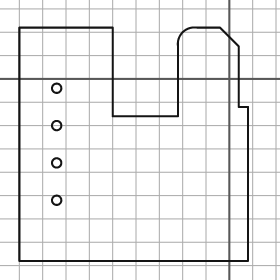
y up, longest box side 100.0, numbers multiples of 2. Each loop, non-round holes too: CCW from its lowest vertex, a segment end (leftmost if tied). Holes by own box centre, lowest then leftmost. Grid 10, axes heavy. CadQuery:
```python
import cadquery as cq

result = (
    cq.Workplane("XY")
    .moveTo(-90.0, -78.0)
    .lineTo(8.0, -78.0)
    .lineTo(8.0, -12.0)
    .lineTo(4.0, -12.0)
    .lineTo(4.0, 14.0)
    .lineTo(-4.0, 22.0)
    .lineTo(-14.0, 22.0)
    .threePointArc((-20.0, 20.0), (-22.0, 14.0))
    .lineTo(-22.0, -16.0)
    .lineTo(-50.0, -16.0)
    .lineTo(-50.0, 22.0)
    .lineTo(-90.0, 22.0)
    .close()
    .moveTo(-74.0, -52.0)
    .circle(2.0)
    .moveTo(-74.0, -36.0)
    .circle(2.0)
    .moveTo(-74.0, -20.0)
    .circle(2.0)
    .moveTo(-74.0, -4.0)
    .circle(2.0)
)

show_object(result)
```